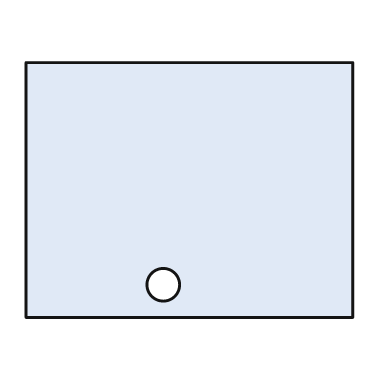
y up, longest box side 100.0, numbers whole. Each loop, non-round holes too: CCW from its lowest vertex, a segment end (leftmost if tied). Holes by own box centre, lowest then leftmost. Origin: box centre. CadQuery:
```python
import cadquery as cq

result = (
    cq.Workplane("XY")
    .moveTo(-50.0, -39.0)
    .lineTo(50.0, -39.0)
    .lineTo(50.0, 39.0)
    .lineTo(-50.0, 39.0)
    .close()
    .moveTo(-8.0, -29.0)
    .circle(5.0)
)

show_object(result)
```